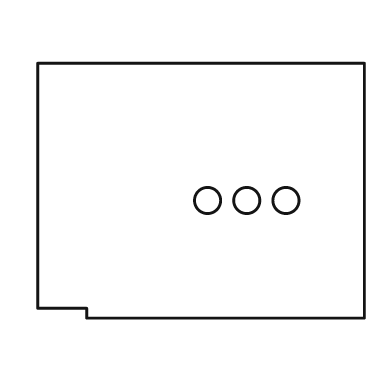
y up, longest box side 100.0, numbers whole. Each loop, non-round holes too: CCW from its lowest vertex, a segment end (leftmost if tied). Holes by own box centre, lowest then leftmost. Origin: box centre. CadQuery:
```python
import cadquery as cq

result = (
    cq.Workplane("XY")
    .moveTo(-35.0, -39.0)
    .lineTo(50.0, -39.0)
    .lineTo(50.0, 39.0)
    .lineTo(-50.0, 39.0)
    .lineTo(-50.0, -36.0)
    .lineTo(-35.0, -36.0)
    .close()
    .moveTo(2.0, -3.0)
    .circle(4.0)
    .moveTo(14.0, -3.0)
    .circle(4.0)
    .moveTo(26.0, -3.0)
    .circle(4.0)
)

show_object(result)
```